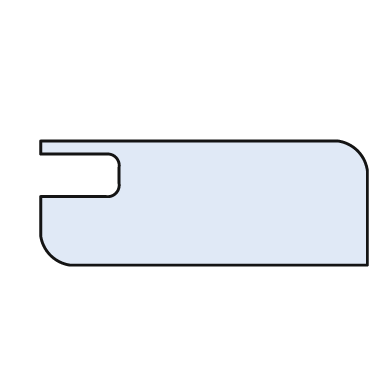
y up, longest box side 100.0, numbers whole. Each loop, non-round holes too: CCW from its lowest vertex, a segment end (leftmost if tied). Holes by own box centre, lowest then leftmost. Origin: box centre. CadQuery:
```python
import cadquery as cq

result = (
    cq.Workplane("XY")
    .moveTo(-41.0, -19.0)
    .lineTo(50.0, -19.0)
    .lineTo(50.0, 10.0)
    .threePointArc((47.0, 16.0), (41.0, 19.0))
    .lineTo(-50.0, 19.0)
    .lineTo(-50.0, 15.0)
    .lineTo(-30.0, 15.0)
    .threePointArc((-27.0, 14.0), (-26.0, 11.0))
    .lineTo(-26.0, 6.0)
    .threePointArc((-27.0, 3.0), (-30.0, 2.0))
    .lineTo(-50.0, 2.0)
    .lineTo(-50.0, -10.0)
    .threePointArc((-47.0, -16.0), (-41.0, -19.0))
    .close()
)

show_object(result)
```